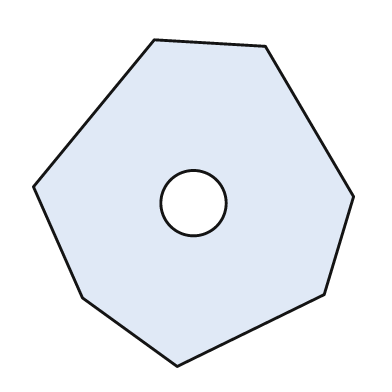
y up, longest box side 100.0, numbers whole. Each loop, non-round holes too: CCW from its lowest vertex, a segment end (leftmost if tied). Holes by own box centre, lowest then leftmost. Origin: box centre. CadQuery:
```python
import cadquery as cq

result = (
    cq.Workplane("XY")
    .moveTo(-5.0, -50.0)
    .lineTo(40.0, -28.0)
    .lineTo(49.0, 2.0)
    .lineTo(22.0, 48.0)
    .lineTo(-12.0, 50.0)
    .lineTo(-49.0, 5.0)
    .lineTo(-34.0, -29.0)
    .close()
    .moveTo(0.0, 0.0)
    .circle(10.0)
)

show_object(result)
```